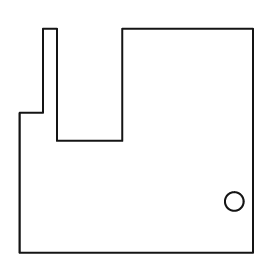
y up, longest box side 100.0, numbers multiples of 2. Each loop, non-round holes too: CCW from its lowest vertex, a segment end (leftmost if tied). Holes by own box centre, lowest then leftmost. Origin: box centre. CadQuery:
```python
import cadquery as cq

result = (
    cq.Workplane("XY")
    .moveTo(-50.0, -48.0)
    .lineTo(50.0, -48.0)
    .lineTo(50.0, 48.0)
    .lineTo(-6.0, 48.0)
    .lineTo(-6.0, 0.0)
    .lineTo(-34.0, 0.0)
    .lineTo(-34.0, 48.0)
    .lineTo(-40.0, 48.0)
    .lineTo(-40.0, 12.0)
    .lineTo(-50.0, 12.0)
    .close()
    .moveTo(42.0, -26.0)
    .circle(4.0)
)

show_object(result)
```